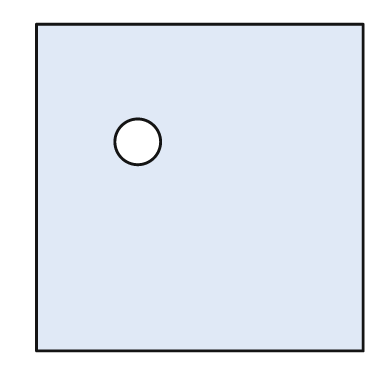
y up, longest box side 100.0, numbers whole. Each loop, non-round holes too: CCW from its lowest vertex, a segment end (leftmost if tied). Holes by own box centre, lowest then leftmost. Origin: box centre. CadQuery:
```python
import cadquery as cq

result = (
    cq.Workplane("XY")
    .moveTo(-50.0, -50.0)
    .lineTo(50.0, -50.0)
    .lineTo(50.0, 50.0)
    .lineTo(-50.0, 50.0)
    .close()
    .moveTo(-19.0, 14.0)
    .circle(7.0)
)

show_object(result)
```